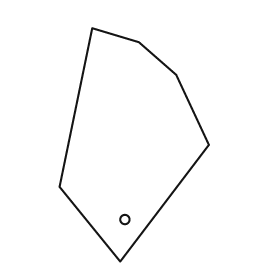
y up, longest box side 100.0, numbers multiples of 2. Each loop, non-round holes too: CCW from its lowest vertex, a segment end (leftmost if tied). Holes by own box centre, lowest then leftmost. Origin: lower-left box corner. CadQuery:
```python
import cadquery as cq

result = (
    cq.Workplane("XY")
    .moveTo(26.0, 0.0)
    .lineTo(64.0, 50.0)
    .lineTo(50.0, 80.0)
    .lineTo(34.0, 94.0)
    .lineTo(14.0, 100.0)
    .lineTo(0.0, 32.0)
    .close()
    .moveTo(28.0, 18.0)
    .circle(2.0)
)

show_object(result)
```